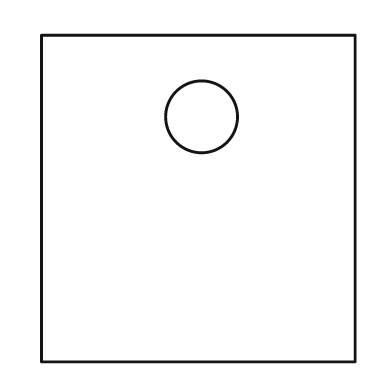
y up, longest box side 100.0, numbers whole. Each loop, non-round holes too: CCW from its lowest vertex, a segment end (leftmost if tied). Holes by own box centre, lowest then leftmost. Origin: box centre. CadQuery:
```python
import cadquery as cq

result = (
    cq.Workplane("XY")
    .moveTo(-48.0, -50.0)
    .lineTo(48.0, -50.0)
    .lineTo(48.0, 50.0)
    .lineTo(-48.0, 50.0)
    .close()
    .moveTo(1.0, 25.0)
    .circle(11.0)
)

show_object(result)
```